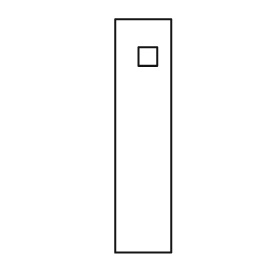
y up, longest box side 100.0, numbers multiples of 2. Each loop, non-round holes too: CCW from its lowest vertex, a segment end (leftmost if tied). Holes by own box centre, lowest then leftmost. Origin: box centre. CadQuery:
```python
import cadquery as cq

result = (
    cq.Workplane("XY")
    .moveTo(-12.0, -50.0)
    .lineTo(12.0, -50.0)
    .lineTo(12.0, 50.0)
    .lineTo(-12.0, 50.0)
    .close()
    .moveTo(-2.0, 30.0)
    .lineTo(6.0, 30.0)
    .lineTo(6.0, 38.0)
    .lineTo(-2.0, 38.0)
    .close()
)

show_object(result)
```